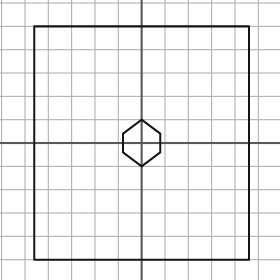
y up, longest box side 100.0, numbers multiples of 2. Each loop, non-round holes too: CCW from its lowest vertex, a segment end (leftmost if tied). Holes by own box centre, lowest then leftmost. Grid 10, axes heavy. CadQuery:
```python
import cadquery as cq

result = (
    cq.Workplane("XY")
    .moveTo(-46.0, -50.0)
    .lineTo(46.0, -50.0)
    .lineTo(46.0, 50.0)
    .lineTo(-46.0, 50.0)
    .close()
    .moveTo(0.0, -10.0)
    .lineTo(8.0, -4.0)
    .lineTo(8.0, 4.0)
    .lineTo(0.0, 10.0)
    .lineTo(-8.0, 4.0)
    .lineTo(-8.0, -4.0)
    .close()
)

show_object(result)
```